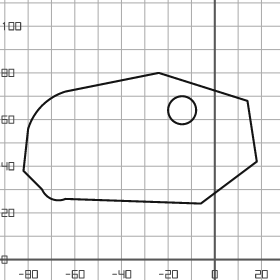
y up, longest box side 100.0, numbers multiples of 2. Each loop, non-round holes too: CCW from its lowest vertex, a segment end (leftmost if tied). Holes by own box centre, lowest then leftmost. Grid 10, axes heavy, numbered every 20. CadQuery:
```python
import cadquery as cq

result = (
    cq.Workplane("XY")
    .moveTo(-6.0, 24.0)
    .lineTo(18.0, 42.0)
    .lineTo(14.0, 68.0)
    .lineTo(-24.0, 80.0)
    .lineTo(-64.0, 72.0)
    .threePointArc((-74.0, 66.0), (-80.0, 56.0))
    .lineTo(-82.0, 38.0)
    .lineTo(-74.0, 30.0)
    .threePointArc((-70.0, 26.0), (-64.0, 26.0))
    .close()
    .moveTo(-14.0, 64.0)
    .circle(6.0)
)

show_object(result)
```